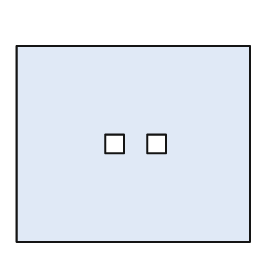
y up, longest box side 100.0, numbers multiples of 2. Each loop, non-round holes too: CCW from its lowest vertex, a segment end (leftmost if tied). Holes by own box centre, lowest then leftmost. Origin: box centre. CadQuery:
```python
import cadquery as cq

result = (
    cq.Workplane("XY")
    .moveTo(-50.0, -42.0)
    .lineTo(50.0, -42.0)
    .lineTo(50.0, 42.0)
    .lineTo(-50.0, 42.0)
    .close()
    .moveTo(-12.0, -4.0)
    .lineTo(-4.0, -4.0)
    .lineTo(-4.0, 4.0)
    .lineTo(-12.0, 4.0)
    .close()
    .moveTo(6.0, -4.0)
    .lineTo(14.0, -4.0)
    .lineTo(14.0, 4.0)
    .lineTo(6.0, 4.0)
    .close()
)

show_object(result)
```